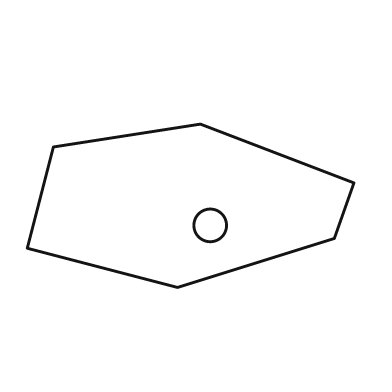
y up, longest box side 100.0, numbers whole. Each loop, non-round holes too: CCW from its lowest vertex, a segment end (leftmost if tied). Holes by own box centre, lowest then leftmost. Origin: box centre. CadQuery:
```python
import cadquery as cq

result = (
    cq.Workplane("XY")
    .moveTo(-4.0, -25.0)
    .lineTo(44.0, -10.0)
    .lineTo(50.0, 7.0)
    .lineTo(3.0, 25.0)
    .lineTo(-42.0, 18.0)
    .lineTo(-50.0, -13.0)
    .close()
    .moveTo(6.0, -6.0)
    .circle(5.0)
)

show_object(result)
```